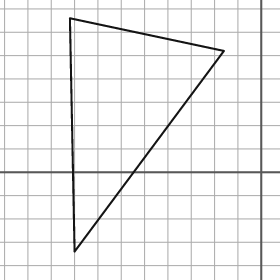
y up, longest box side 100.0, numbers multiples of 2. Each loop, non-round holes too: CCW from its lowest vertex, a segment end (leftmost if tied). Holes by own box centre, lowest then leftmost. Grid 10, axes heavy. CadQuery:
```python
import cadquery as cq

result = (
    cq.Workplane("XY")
    .moveTo(-80.0, -34.0)
    .lineTo(-16.0, 52.0)
    .lineTo(-82.0, 66.0)
    .close()
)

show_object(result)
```